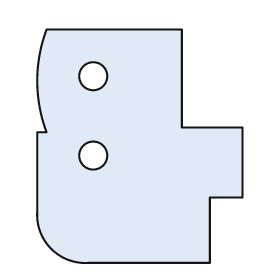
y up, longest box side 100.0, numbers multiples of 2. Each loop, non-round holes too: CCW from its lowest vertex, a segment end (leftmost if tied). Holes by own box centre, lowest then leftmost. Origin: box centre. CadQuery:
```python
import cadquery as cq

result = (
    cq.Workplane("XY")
    .moveTo(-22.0, -50.0)
    .lineTo(30.0, -50.0)
    .lineTo(30.0, -22.0)
    .lineTo(44.0, -22.0)
    .lineTo(44.0, 8.0)
    .lineTo(18.0, 8.0)
    .lineTo(18.0, 50.0)
    .lineTo(-40.0, 50.0)
    .threePointArc((-44.0, 28.0), (-40.0, 6.0))
    .lineTo(-44.0, 6.0)
    .lineTo(-44.0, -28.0)
    .threePointArc((-38.0, -44.0), (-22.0, -50.0))
    .close()
    .moveTo(-20.0, -4.0)
    .circle(6.0)
    .moveTo(-20.0, 30.0)
    .circle(6.0)
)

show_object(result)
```